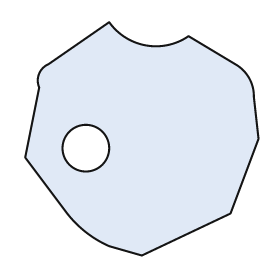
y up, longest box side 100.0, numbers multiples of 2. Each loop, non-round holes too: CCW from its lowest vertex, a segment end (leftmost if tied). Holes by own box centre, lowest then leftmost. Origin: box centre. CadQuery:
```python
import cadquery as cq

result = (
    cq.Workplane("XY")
    .moveTo(0.0, -50.0)
    .lineTo(38.0, -32.0)
    .lineTo(50.0, 0.0)
    .lineTo(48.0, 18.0)
    .threePointArc((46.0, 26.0), (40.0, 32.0))
    .lineTo(20.0, 44.0)
    .threePointArc((2.0, 40.0), (-14.0, 50.0))
    .lineTo(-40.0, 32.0)
    .threePointArc((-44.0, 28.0), (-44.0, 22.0))
    .lineTo(-50.0, -8.0)
    .lineTo(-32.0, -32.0)
    .threePointArc((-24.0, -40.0), (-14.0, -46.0))
    .close()
    .moveTo(-24.0, -4.0)
    .circle(10.0)
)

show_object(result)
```